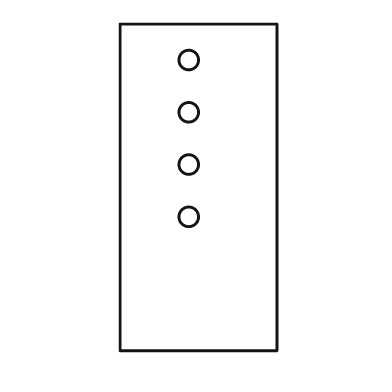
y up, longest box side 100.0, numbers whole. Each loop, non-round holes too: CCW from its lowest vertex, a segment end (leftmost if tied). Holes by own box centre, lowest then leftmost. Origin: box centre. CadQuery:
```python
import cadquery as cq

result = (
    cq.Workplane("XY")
    .moveTo(-24.0, -50.0)
    .lineTo(24.0, -50.0)
    .lineTo(24.0, 50.0)
    .lineTo(-24.0, 50.0)
    .close()
    .moveTo(-3.0, -9.0)
    .circle(3.0)
    .moveTo(-3.0, 7.0)
    .circle(3.0)
    .moveTo(-3.0, 23.0)
    .circle(3.0)
    .moveTo(-3.0, 39.0)
    .circle(3.0)
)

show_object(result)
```